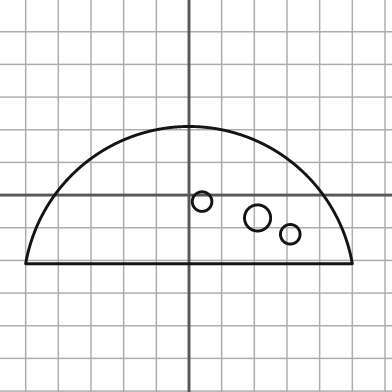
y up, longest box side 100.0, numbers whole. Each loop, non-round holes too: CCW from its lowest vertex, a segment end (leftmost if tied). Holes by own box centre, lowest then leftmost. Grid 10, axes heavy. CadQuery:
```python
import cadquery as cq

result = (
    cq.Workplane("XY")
    .moveTo(-50.0, -21.0)
    .lineTo(50.0, -21.0)
    .threePointArc((0.0, 21.0), (-50.0, -21.0))
    .close()
    .moveTo(31.0, -12.0)
    .circle(3.0)
    .moveTo(21.0, -7.0)
    .circle(4.0)
    .moveTo(4.0, -2.0)
    .circle(3.0)
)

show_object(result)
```